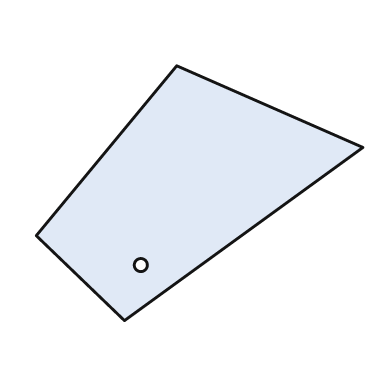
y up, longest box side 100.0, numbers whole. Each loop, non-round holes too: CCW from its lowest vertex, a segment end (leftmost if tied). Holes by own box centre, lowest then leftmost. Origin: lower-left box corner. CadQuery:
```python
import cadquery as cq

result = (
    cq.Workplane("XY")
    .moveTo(27.0, 0.0)
    .lineTo(100.0, 53.0)
    .lineTo(43.0, 78.0)
    .lineTo(0.0, 26.0)
    .close()
    .moveTo(32.0, 17.0)
    .circle(2.0)
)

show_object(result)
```